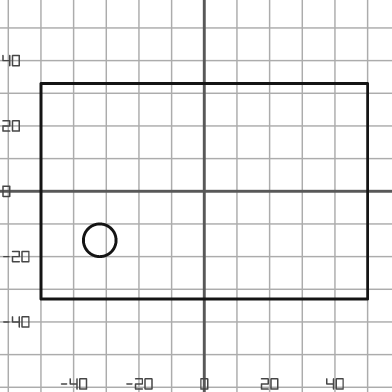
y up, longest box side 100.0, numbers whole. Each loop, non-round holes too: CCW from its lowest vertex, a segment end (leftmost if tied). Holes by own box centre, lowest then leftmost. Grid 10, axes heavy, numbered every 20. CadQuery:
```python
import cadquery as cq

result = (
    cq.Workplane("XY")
    .moveTo(-50.0, -33.0)
    .lineTo(50.0, -33.0)
    .lineTo(50.0, 33.0)
    .lineTo(-50.0, 33.0)
    .close()
    .moveTo(-32.0, -15.0)
    .circle(5.0)
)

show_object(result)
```